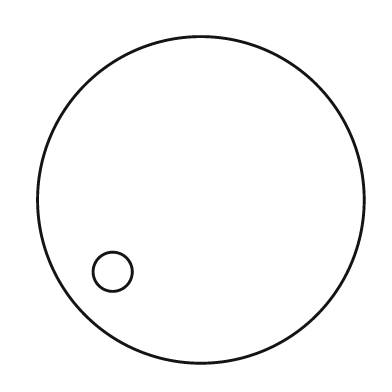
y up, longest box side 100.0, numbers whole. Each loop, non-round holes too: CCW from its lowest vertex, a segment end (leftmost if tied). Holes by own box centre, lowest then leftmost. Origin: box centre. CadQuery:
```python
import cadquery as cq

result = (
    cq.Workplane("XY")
    .moveTo(0.0, 0.0)
    .circle(50.0)
    .moveTo(-27.0, -22.0)
    .circle(6.0)
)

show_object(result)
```